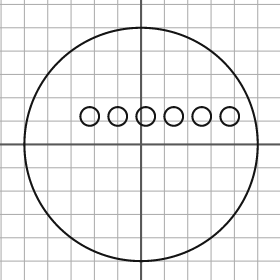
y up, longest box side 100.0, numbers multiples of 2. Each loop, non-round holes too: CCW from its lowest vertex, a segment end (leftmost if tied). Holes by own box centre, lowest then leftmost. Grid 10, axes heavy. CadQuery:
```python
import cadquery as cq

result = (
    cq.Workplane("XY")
    .moveTo(0.0, 0.0)
    .circle(50.0)
    .moveTo(-22.0, 12.0)
    .circle(4.0)
    .moveTo(-10.0, 12.0)
    .circle(4.0)
    .moveTo(2.0, 12.0)
    .circle(4.0)
    .moveTo(14.0, 12.0)
    .circle(4.0)
    .moveTo(26.0, 12.0)
    .circle(4.0)
    .moveTo(38.0, 12.0)
    .circle(4.0)
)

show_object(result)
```